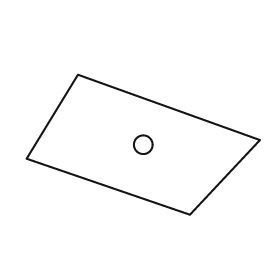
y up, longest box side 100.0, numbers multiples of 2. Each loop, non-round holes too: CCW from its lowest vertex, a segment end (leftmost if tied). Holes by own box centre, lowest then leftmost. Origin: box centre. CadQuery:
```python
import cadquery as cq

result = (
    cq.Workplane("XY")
    .moveTo(20.0, -30.0)
    .lineTo(50.0, 2.0)
    .lineTo(-28.0, 30.0)
    .lineTo(-50.0, -6.0)
    .close()
    .moveTo(0.0, 0.0)
    .circle(4.0)
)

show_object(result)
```